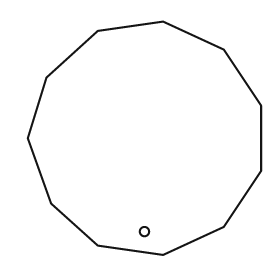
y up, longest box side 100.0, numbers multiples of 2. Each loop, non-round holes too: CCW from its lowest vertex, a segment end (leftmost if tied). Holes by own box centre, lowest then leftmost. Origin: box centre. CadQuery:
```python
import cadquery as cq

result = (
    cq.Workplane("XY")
    .moveTo(8.0, -50.0)
    .lineTo(34.0, -38.0)
    .lineTo(50.0, -14.0)
    .lineTo(50.0, 14.0)
    .lineTo(34.0, 38.0)
    .lineTo(8.0, 50.0)
    .lineTo(-20.0, 46.0)
    .lineTo(-42.0, 26.0)
    .lineTo(-50.0, 0.0)
    .lineTo(-40.0, -28.0)
    .lineTo(-20.0, -46.0)
    .close()
    .moveTo(0.0, -40.0)
    .circle(2.0)
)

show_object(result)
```